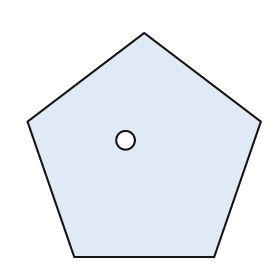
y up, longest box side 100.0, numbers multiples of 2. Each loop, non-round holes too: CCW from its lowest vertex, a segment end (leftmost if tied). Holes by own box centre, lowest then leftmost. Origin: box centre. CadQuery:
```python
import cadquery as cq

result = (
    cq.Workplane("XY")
    .moveTo(-30.0, -48.0)
    .lineTo(30.0, -48.0)
    .lineTo(50.0, 10.0)
    .lineTo(0.0, 48.0)
    .lineTo(-50.0, 10.0)
    .close()
    .moveTo(-8.0, 2.0)
    .circle(4.0)
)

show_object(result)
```